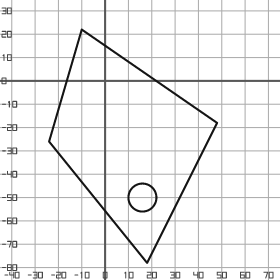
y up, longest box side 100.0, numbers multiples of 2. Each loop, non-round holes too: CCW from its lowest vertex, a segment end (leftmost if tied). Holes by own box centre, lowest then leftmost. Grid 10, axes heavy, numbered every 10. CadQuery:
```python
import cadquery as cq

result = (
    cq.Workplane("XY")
    .moveTo(18.0, -78.0)
    .lineTo(48.0, -18.0)
    .lineTo(-10.0, 22.0)
    .lineTo(-24.0, -26.0)
    .close()
    .moveTo(16.0, -50.0)
    .circle(6.0)
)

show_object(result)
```